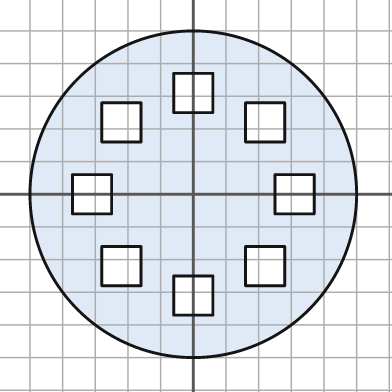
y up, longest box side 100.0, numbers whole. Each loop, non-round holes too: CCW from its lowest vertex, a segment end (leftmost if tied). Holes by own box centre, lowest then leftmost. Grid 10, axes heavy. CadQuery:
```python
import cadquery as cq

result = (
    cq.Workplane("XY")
    .moveTo(0.0, 0.0)
    .circle(50.0)
    .moveTo(-6.0, -37.0)
    .lineTo(6.0, -37.0)
    .lineTo(6.0, -25.0)
    .lineTo(-6.0, -25.0)
    .close()
    .moveTo(-28.0, -28.0)
    .lineTo(-16.0, -28.0)
    .lineTo(-16.0, -16.0)
    .lineTo(-28.0, -16.0)
    .close()
    .moveTo(16.0, -28.0)
    .lineTo(28.0, -28.0)
    .lineTo(28.0, -16.0)
    .lineTo(16.0, -16.0)
    .close()
    .moveTo(-37.0, -6.0)
    .lineTo(-25.0, -6.0)
    .lineTo(-25.0, 6.0)
    .lineTo(-37.0, 6.0)
    .close()
    .moveTo(25.0, -6.0)
    .lineTo(37.0, -6.0)
    .lineTo(37.0, 6.0)
    .lineTo(25.0, 6.0)
    .close()
    .moveTo(-28.0, 16.0)
    .lineTo(-16.0, 16.0)
    .lineTo(-16.0, 28.0)
    .lineTo(-28.0, 28.0)
    .close()
    .moveTo(16.0, 16.0)
    .lineTo(28.0, 16.0)
    .lineTo(28.0, 28.0)
    .lineTo(16.0, 28.0)
    .close()
    .moveTo(-6.0, 25.0)
    .lineTo(6.0, 25.0)
    .lineTo(6.0, 37.0)
    .lineTo(-6.0, 37.0)
    .close()
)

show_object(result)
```